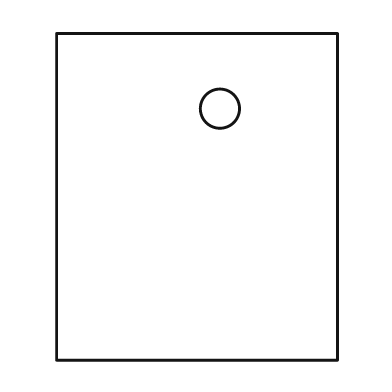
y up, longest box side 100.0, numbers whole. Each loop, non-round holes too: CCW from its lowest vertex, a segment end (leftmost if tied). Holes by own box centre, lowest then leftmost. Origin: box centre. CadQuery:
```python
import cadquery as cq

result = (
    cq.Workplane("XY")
    .moveTo(-43.0, -50.0)
    .lineTo(43.0, -50.0)
    .lineTo(43.0, 50.0)
    .lineTo(-43.0, 50.0)
    .close()
    .moveTo(7.0, 27.0)
    .circle(6.0)
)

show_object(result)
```